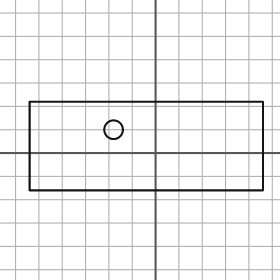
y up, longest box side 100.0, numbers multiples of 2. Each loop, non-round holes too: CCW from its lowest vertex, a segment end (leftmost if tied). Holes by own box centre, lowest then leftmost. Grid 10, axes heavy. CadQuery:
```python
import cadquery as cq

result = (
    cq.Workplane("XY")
    .moveTo(-54.0, -16.0)
    .lineTo(46.0, -16.0)
    .lineTo(46.0, 22.0)
    .lineTo(-54.0, 22.0)
    .close()
    .moveTo(-18.0, 10.0)
    .circle(4.0)
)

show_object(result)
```